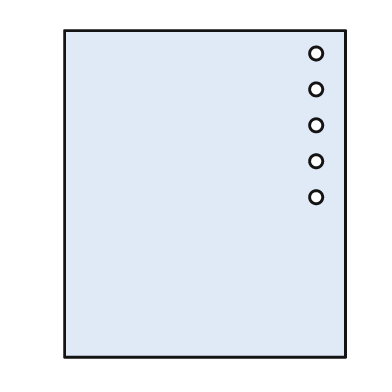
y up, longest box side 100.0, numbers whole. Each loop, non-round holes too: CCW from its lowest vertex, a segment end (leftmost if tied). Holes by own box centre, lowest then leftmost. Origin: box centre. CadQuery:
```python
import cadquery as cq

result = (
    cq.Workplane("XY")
    .moveTo(-43.0, -50.0)
    .lineTo(43.0, -50.0)
    .lineTo(43.0, 50.0)
    .lineTo(-43.0, 50.0)
    .close()
    .moveTo(34.0, -1.0)
    .circle(2.0)
    .moveTo(34.0, 10.0)
    .circle(2.0)
    .moveTo(34.0, 21.0)
    .circle(2.0)
    .moveTo(34.0, 32.0)
    .circle(2.0)
    .moveTo(34.0, 43.0)
    .circle(2.0)
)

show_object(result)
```